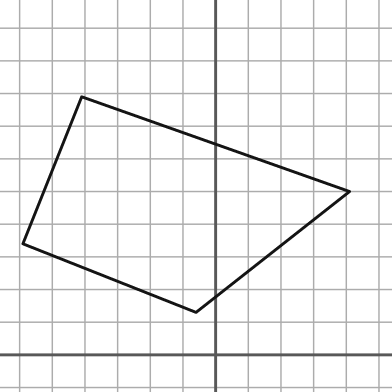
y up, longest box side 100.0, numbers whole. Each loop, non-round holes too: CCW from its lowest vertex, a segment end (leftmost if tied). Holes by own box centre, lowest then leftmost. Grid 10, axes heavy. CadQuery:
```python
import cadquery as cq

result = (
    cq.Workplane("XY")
    .moveTo(-6.0, 13.0)
    .lineTo(41.0, 50.0)
    .lineTo(-41.0, 79.0)
    .lineTo(-59.0, 34.0)
    .close()
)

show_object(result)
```